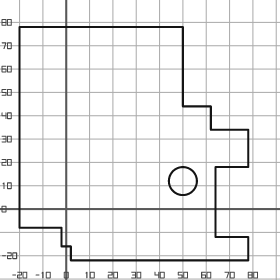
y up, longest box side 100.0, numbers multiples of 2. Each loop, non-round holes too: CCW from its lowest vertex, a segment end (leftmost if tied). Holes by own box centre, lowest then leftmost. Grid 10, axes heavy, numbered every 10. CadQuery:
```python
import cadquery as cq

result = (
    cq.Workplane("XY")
    .moveTo(2.0, -22.0)
    .lineTo(78.0, -22.0)
    .lineTo(78.0, -12.0)
    .lineTo(64.0, -12.0)
    .lineTo(64.0, 18.0)
    .lineTo(78.0, 18.0)
    .lineTo(78.0, 34.0)
    .lineTo(62.0, 34.0)
    .lineTo(62.0, 44.0)
    .lineTo(50.0, 44.0)
    .lineTo(50.0, 78.0)
    .lineTo(-20.0, 78.0)
    .lineTo(-20.0, -8.0)
    .lineTo(-2.0, -8.0)
    .lineTo(-2.0, -16.0)
    .lineTo(2.0, -16.0)
    .close()
    .moveTo(50.0, 12.0)
    .circle(6.0)
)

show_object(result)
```